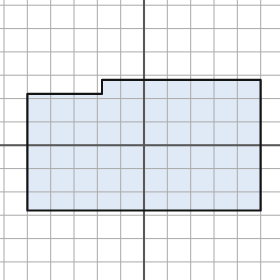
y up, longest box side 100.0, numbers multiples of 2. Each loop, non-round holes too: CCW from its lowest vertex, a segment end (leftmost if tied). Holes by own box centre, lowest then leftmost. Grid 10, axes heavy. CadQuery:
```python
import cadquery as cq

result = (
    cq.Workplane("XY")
    .moveTo(-50.0, -28.0)
    .lineTo(50.0, -28.0)
    .lineTo(50.0, 28.0)
    .lineTo(-18.0, 28.0)
    .lineTo(-18.0, 22.0)
    .lineTo(-50.0, 22.0)
    .close()
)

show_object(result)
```